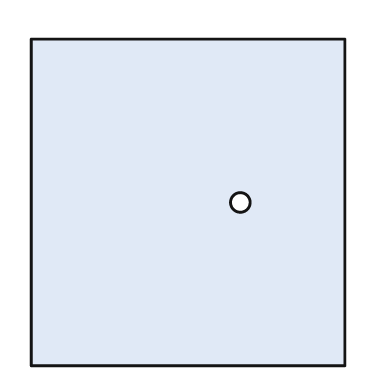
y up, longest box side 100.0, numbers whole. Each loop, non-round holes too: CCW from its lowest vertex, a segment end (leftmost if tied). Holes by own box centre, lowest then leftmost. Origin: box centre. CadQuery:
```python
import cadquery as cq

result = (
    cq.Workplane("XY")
    .moveTo(-48.0, -50.0)
    .lineTo(48.0, -50.0)
    .lineTo(48.0, 50.0)
    .lineTo(-48.0, 50.0)
    .close()
    .moveTo(16.0, 0.0)
    .circle(3.0)
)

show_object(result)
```